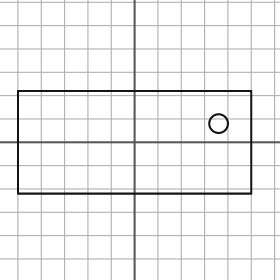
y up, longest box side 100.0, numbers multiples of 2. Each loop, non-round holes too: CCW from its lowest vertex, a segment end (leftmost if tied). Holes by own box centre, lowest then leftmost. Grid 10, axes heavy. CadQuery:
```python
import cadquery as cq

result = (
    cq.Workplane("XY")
    .moveTo(-50.0, -22.0)
    .lineTo(50.0, -22.0)
    .lineTo(50.0, 22.0)
    .lineTo(-50.0, 22.0)
    .close()
    .moveTo(36.0, 8.0)
    .circle(4.0)
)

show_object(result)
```